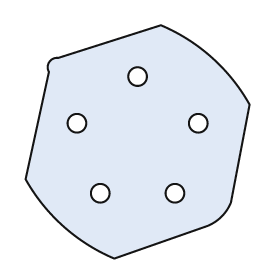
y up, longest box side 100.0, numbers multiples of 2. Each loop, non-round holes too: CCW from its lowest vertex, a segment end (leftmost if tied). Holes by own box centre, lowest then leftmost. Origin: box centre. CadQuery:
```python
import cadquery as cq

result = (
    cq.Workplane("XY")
    .moveTo(-10.0, -50.0)
    .lineTo(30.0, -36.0)
    .threePointArc((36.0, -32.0), (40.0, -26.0))
    .lineTo(48.0, 16.0)
    .threePointArc((32.0, 36.0), (10.0, 50.0))
    .lineTo(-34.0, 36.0)
    .threePointArc((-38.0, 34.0), (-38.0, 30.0))
    .lineTo(-48.0, -16.0)
    .threePointArc((-32.0, -36.0), (-10.0, -50.0))
    .close()
    .moveTo(-16.0, -22.0)
    .circle(4.0)
    .moveTo(16.0, -22.0)
    .circle(4.0)
    .moveTo(-26.0, 8.0)
    .circle(4.0)
    .moveTo(26.0, 8.0)
    .circle(4.0)
    .moveTo(0.0, 28.0)
    .circle(4.0)
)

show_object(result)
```